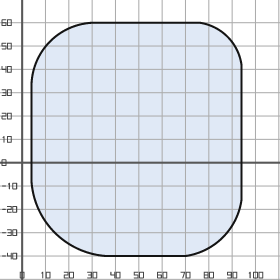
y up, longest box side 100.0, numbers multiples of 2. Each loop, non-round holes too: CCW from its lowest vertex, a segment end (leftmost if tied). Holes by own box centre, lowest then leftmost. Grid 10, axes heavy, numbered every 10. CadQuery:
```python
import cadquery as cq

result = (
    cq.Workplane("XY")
    .moveTo(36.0, -40.0)
    .lineTo(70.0, -40.0)
    .threePointArc((86.0, -32.0), (94.0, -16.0))
    .lineTo(94.0, 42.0)
    .threePointArc((88.0, 54.0), (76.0, 60.0))
    .lineTo(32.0, 60.0)
    .threePointArc((12.0, 52.0), (4.0, 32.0))
    .lineTo(4.0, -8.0)
    .threePointArc((14.0, -30.0), (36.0, -40.0))
    .close()
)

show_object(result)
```